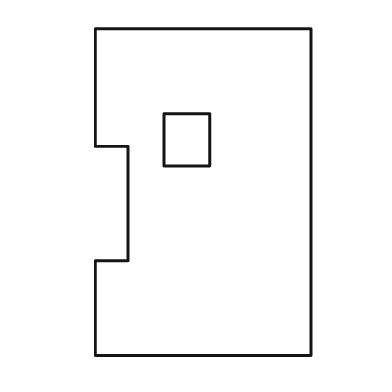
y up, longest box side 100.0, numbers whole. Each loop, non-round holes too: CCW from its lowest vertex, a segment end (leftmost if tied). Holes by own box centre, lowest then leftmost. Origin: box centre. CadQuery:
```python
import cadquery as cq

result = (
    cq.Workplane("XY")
    .moveTo(-33.0, -50.0)
    .lineTo(33.0, -50.0)
    .lineTo(33.0, 50.0)
    .lineTo(-33.0, 50.0)
    .lineTo(-33.0, 14.0)
    .lineTo(-23.0, 14.0)
    .lineTo(-23.0, -21.0)
    .lineTo(-33.0, -21.0)
    .close()
    .moveTo(-12.0, 8.0)
    .lineTo(2.0, 8.0)
    .lineTo(2.0, 24.0)
    .lineTo(-12.0, 24.0)
    .close()
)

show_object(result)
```